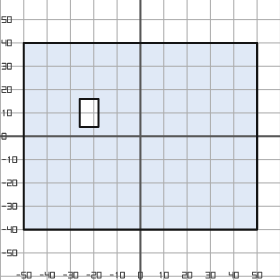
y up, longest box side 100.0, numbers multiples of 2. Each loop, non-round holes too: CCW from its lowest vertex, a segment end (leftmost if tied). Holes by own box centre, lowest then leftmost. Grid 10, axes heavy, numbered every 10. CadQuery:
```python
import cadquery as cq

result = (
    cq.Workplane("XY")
    .moveTo(-50.0, -40.0)
    .lineTo(50.0, -40.0)
    .lineTo(50.0, 40.0)
    .lineTo(-50.0, 40.0)
    .close()
    .moveTo(-26.0, 4.0)
    .lineTo(-18.0, 4.0)
    .lineTo(-18.0, 16.0)
    .lineTo(-26.0, 16.0)
    .close()
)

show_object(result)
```